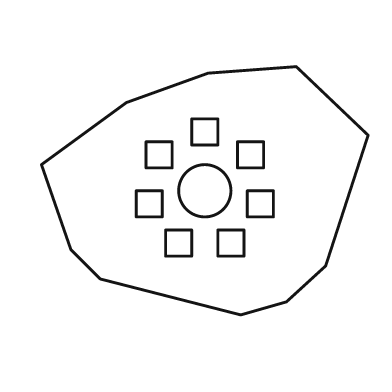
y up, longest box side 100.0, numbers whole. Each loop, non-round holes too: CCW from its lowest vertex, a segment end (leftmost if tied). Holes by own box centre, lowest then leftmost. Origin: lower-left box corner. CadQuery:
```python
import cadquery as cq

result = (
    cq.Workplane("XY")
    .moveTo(61.0, 0.0)
    .lineTo(75.0, 4.0)
    .lineTo(87.0, 15.0)
    .lineTo(100.0, 55.0)
    .lineTo(78.0, 76.0)
    .lineTo(51.0, 74.0)
    .lineTo(26.0, 65.0)
    .lineTo(0.0, 46.0)
    .lineTo(9.0, 20.0)
    .lineTo(18.0, 11.0)
    .close()
    .moveTo(38.0, 18.0)
    .lineTo(46.0, 18.0)
    .lineTo(46.0, 26.0)
    .lineTo(38.0, 26.0)
    .close()
    .moveTo(54.0, 18.0)
    .lineTo(62.0, 18.0)
    .lineTo(62.0, 26.0)
    .lineTo(54.0, 26.0)
    .close()
    .moveTo(29.0, 30.0)
    .lineTo(37.0, 30.0)
    .lineTo(37.0, 38.0)
    .lineTo(29.0, 38.0)
    .close()
    .moveTo(63.0, 30.0)
    .lineTo(71.0, 30.0)
    .lineTo(71.0, 38.0)
    .lineTo(63.0, 38.0)
    .close()
    .moveTo(50.0, 38.0)
    .circle(8.0)
    .moveTo(32.0, 45.0)
    .lineTo(40.0, 45.0)
    .lineTo(40.0, 53.0)
    .lineTo(32.0, 53.0)
    .close()
    .moveTo(60.0, 45.0)
    .lineTo(68.0, 45.0)
    .lineTo(68.0, 53.0)
    .lineTo(60.0, 53.0)
    .close()
    .moveTo(46.0, 52.0)
    .lineTo(54.0, 52.0)
    .lineTo(54.0, 60.0)
    .lineTo(46.0, 60.0)
    .close()
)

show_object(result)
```